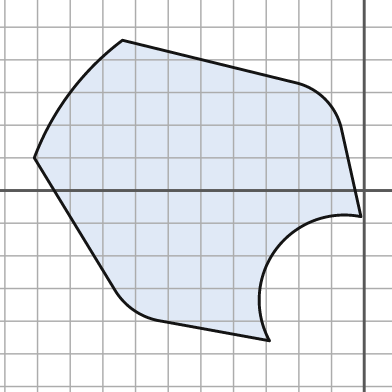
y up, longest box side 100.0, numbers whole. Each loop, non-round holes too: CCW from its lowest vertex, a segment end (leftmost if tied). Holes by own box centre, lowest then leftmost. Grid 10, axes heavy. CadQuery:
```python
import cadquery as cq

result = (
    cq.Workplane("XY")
    .moveTo(-29.0, -46.0)
    .threePointArc((-27.0, -18.0), (-1.0, -8.0))
    .lineTo(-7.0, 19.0)
    .threePointArc((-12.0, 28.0), (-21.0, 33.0))
    .lineTo(-74.0, 46.0)
    .threePointArc((-90.0, 30.0), (-101.0, 10.0))
    .lineTo(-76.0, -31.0)
    .threePointArc((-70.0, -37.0), (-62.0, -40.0))
    .close()
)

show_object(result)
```